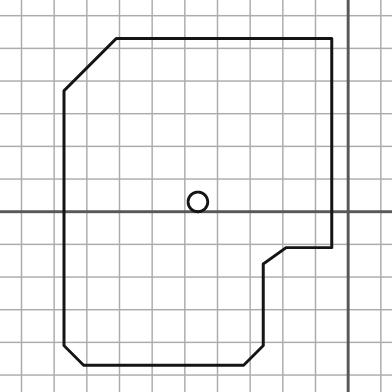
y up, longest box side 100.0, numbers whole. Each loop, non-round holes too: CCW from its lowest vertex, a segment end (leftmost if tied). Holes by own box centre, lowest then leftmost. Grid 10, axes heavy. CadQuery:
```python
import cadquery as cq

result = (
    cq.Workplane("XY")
    .moveTo(-81.0, -47.0)
    .lineTo(-32.0, -47.0)
    .lineTo(-26.0, -41.0)
    .lineTo(-26.0, -16.0)
    .lineTo(-19.0, -11.0)
    .lineTo(-5.0, -11.0)
    .lineTo(-5.0, 53.0)
    .lineTo(-71.0, 53.0)
    .lineTo(-87.0, 37.0)
    .lineTo(-87.0, -41.0)
    .close()
    .moveTo(-46.0, 3.0)
    .circle(3.0)
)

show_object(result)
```